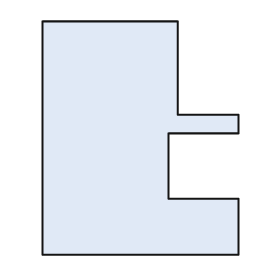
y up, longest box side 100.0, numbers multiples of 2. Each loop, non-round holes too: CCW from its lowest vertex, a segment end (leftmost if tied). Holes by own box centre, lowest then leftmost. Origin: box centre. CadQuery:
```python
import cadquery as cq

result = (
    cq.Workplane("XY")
    .moveTo(-42.0, -50.0)
    .lineTo(42.0, -50.0)
    .lineTo(42.0, -26.0)
    .lineTo(12.0, -26.0)
    .lineTo(12.0, 2.0)
    .lineTo(42.0, 2.0)
    .lineTo(42.0, 10.0)
    .lineTo(16.0, 10.0)
    .lineTo(16.0, 50.0)
    .lineTo(-42.0, 50.0)
    .close()
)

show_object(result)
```